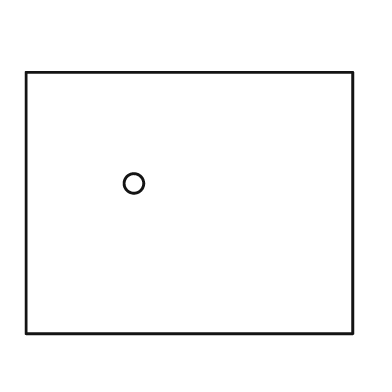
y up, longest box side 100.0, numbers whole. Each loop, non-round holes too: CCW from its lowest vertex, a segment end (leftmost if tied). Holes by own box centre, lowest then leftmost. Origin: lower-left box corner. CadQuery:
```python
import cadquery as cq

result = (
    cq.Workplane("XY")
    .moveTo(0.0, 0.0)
    .lineTo(100.0, 0.0)
    .lineTo(100.0, 80.0)
    .lineTo(0.0, 80.0)
    .close()
    .moveTo(33.0, 46.0)
    .circle(3.0)
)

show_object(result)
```